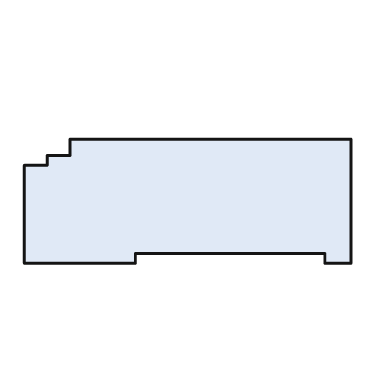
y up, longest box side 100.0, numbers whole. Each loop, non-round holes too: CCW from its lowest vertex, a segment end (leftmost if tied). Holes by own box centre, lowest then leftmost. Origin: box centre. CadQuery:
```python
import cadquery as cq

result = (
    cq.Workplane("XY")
    .moveTo(-50.0, -19.0)
    .lineTo(-16.0, -19.0)
    .lineTo(-16.0, -16.0)
    .lineTo(42.0, -16.0)
    .lineTo(42.0, -19.0)
    .lineTo(50.0, -19.0)
    .lineTo(50.0, 19.0)
    .lineTo(-36.0, 19.0)
    .lineTo(-36.0, 14.0)
    .lineTo(-43.0, 14.0)
    .lineTo(-43.0, 11.0)
    .lineTo(-50.0, 11.0)
    .close()
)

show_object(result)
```